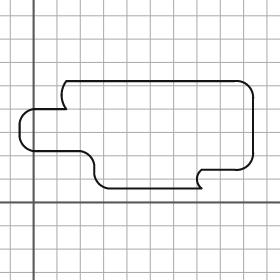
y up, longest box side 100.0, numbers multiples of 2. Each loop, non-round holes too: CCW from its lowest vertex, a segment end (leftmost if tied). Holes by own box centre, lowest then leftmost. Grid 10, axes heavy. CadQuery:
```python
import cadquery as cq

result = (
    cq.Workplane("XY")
    .moveTo(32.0, 6.0)
    .lineTo(72.0, 6.0)
    .threePointArc((70.0, 10.0), (72.0, 14.0))
    .lineTo(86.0, 14.0)
    .threePointArc((92.0, 16.0), (94.0, 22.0))
    .lineTo(94.0, 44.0)
    .threePointArc((92.0, 50.0), (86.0, 52.0))
    .lineTo(14.0, 52.0)
    .threePointArc((12.0, 46.0), (14.0, 40.0))
    .lineTo(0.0, 40.0)
    .threePointArc((-4.0, 38.0), (-6.0, 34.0))
    .lineTo(-6.0, 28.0)
    .threePointArc((-4.0, 24.0), (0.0, 22.0))
    .lineTo(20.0, 22.0)
    .threePointArc((24.0, 20.0), (26.0, 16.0))
    .lineTo(26.0, 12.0)
    .threePointArc((28.0, 8.0), (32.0, 6.0))
    .close()
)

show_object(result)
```